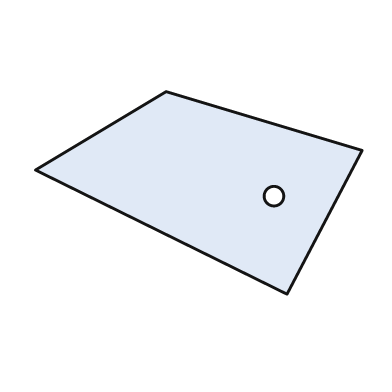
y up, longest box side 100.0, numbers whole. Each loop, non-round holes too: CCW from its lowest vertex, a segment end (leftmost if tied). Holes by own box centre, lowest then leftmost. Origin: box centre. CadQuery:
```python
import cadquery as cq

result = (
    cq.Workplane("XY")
    .moveTo(27.0, -31.0)
    .lineTo(50.0, 13.0)
    .lineTo(-10.0, 31.0)
    .lineTo(-50.0, 7.0)
    .close()
    .moveTo(23.0, -1.0)
    .circle(3.0)
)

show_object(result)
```